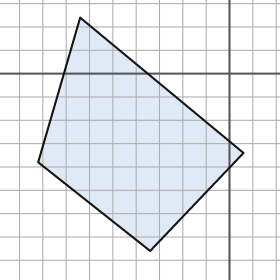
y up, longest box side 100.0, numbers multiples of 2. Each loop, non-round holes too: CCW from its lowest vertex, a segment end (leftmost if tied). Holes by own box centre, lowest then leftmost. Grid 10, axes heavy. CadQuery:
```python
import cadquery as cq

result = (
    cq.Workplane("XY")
    .moveTo(-34.0, -76.0)
    .lineTo(6.0, -34.0)
    .lineTo(-64.0, 24.0)
    .lineTo(-82.0, -38.0)
    .close()
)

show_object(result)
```